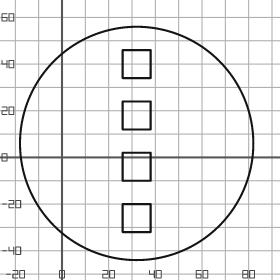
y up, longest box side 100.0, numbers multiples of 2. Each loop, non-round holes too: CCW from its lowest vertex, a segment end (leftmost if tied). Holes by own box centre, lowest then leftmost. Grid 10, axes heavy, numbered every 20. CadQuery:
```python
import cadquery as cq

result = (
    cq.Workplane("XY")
    .moveTo(32.0, 6.0)
    .circle(50.0)
    .moveTo(26.0, -32.0)
    .lineTo(38.0, -32.0)
    .lineTo(38.0, -20.0)
    .lineTo(26.0, -20.0)
    .close()
    .moveTo(26.0, -10.0)
    .lineTo(38.0, -10.0)
    .lineTo(38.0, 2.0)
    .lineTo(26.0, 2.0)
    .close()
    .moveTo(26.0, 12.0)
    .lineTo(38.0, 12.0)
    .lineTo(38.0, 24.0)
    .lineTo(26.0, 24.0)
    .close()
    .moveTo(26.0, 34.0)
    .lineTo(38.0, 34.0)
    .lineTo(38.0, 46.0)
    .lineTo(26.0, 46.0)
    .close()
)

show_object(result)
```